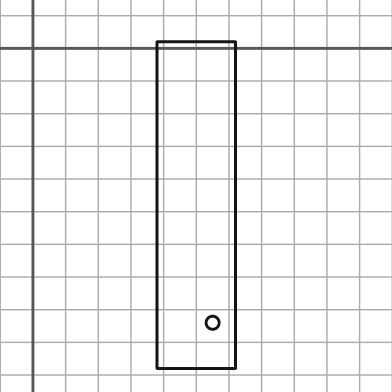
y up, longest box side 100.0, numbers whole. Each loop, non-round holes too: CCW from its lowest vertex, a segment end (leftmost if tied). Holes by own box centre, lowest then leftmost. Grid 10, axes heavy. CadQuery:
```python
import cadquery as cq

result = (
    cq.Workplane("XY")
    .moveTo(38.0, -98.0)
    .lineTo(62.0, -98.0)
    .lineTo(62.0, 2.0)
    .lineTo(38.0, 2.0)
    .close()
    .moveTo(55.0, -84.0)
    .circle(2.0)
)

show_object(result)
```